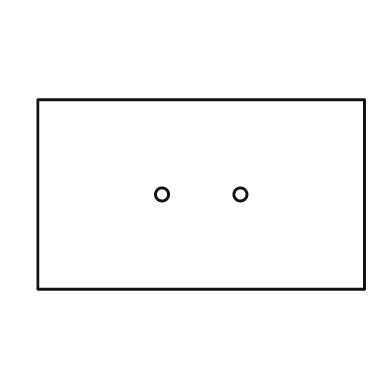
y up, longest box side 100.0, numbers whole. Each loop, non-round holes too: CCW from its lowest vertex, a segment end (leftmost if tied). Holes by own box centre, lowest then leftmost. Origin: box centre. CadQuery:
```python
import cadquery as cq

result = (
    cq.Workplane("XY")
    .moveTo(-50.0, -29.0)
    .lineTo(50.0, -29.0)
    .lineTo(50.0, 29.0)
    .lineTo(-50.0, 29.0)
    .close()
    .moveTo(-12.0, 0.0)
    .circle(2.0)
    .moveTo(12.0, 0.0)
    .circle(2.0)
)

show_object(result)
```